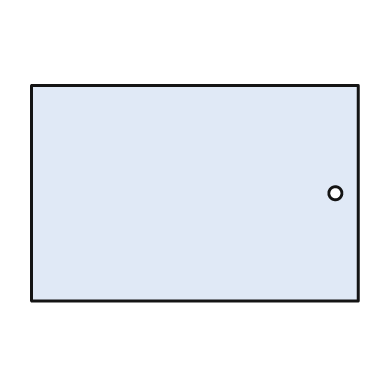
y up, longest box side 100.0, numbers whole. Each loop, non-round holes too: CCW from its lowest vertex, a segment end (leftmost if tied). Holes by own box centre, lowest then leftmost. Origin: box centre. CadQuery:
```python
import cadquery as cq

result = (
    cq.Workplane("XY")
    .moveTo(-50.0, -33.0)
    .lineTo(50.0, -33.0)
    .lineTo(50.0, 33.0)
    .lineTo(-50.0, 33.0)
    .close()
    .moveTo(43.0, 0.0)
    .circle(2.0)
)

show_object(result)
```